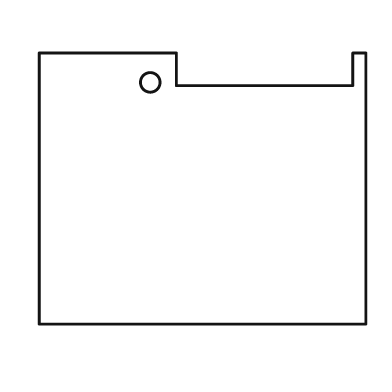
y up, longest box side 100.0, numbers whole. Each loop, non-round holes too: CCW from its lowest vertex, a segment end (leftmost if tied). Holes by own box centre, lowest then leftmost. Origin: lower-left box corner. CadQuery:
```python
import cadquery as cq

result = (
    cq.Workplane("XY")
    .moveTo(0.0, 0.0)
    .lineTo(100.0, 0.0)
    .lineTo(100.0, 83.0)
    .lineTo(96.0, 83.0)
    .lineTo(96.0, 73.0)
    .lineTo(42.0, 73.0)
    .lineTo(42.0, 83.0)
    .lineTo(0.0, 83.0)
    .close()
    .moveTo(34.0, 74.0)
    .circle(3.0)
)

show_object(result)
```